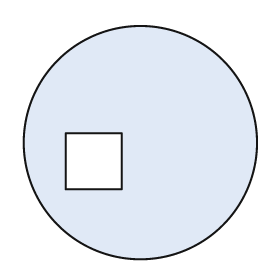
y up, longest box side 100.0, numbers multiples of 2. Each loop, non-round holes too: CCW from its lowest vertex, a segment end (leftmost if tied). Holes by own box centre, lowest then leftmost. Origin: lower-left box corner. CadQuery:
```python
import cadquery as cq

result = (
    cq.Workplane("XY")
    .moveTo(50.0, 50.0)
    .circle(50.0)
    .moveTo(18.0, 30.0)
    .lineTo(42.0, 30.0)
    .lineTo(42.0, 54.0)
    .lineTo(18.0, 54.0)
    .close()
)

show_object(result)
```